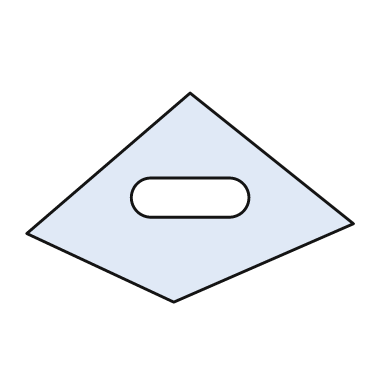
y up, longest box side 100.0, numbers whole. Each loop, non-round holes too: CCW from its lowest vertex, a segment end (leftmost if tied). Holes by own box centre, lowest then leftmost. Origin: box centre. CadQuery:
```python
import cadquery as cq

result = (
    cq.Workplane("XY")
    .moveTo(-5.0, -32.0)
    .lineTo(50.0, -8.0)
    .lineTo(0.0, 32.0)
    .lineTo(-50.0, -11.0)
    .close()
    .moveTo(-12.0, -6.0)
    .lineTo(12.0, -6.0)
    .threePointArc((18.0, 0.0), (12.0, 6.0))
    .lineTo(-12.0, 6.0)
    .threePointArc((-18.0, 0.0), (-12.0, -6.0))
    .close()
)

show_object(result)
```